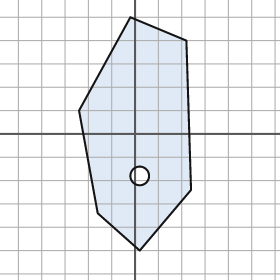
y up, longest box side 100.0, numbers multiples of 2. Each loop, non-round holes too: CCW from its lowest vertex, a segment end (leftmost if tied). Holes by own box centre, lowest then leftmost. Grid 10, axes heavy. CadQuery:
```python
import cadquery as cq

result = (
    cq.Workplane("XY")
    .moveTo(2.0, -50.0)
    .lineTo(24.0, -24.0)
    .lineTo(22.0, 40.0)
    .lineTo(-2.0, 50.0)
    .lineTo(-24.0, 10.0)
    .lineTo(-16.0, -34.0)
    .close()
    .moveTo(2.0, -18.0)
    .circle(4.0)
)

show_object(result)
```